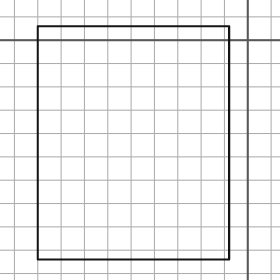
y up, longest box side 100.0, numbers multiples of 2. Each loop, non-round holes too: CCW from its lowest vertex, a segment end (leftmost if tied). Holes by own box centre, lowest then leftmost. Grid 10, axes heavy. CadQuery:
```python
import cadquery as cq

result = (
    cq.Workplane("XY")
    .moveTo(-90.0, -94.0)
    .lineTo(-8.0, -94.0)
    .lineTo(-8.0, 6.0)
    .lineTo(-90.0, 6.0)
    .close()
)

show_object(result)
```